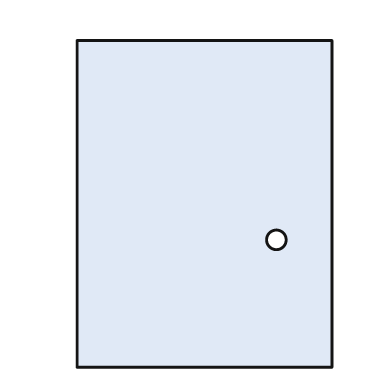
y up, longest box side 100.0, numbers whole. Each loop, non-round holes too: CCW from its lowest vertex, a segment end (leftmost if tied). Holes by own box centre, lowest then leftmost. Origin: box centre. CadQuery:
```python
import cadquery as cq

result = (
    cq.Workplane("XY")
    .moveTo(-39.0, -50.0)
    .lineTo(39.0, -50.0)
    .lineTo(39.0, 50.0)
    .lineTo(-39.0, 50.0)
    .close()
    .moveTo(22.0, -11.0)
    .circle(3.0)
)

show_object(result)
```